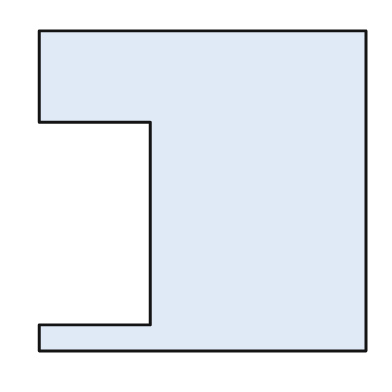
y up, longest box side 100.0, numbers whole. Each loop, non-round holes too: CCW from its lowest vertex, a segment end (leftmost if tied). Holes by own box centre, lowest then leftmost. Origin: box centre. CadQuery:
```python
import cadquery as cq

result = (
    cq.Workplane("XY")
    .moveTo(-50.0, -49.0)
    .lineTo(50.0, -49.0)
    .lineTo(50.0, 49.0)
    .lineTo(-50.0, 49.0)
    .lineTo(-50.0, 21.0)
    .lineTo(-16.0, 21.0)
    .lineTo(-16.0, -41.0)
    .lineTo(-50.0, -41.0)
    .close()
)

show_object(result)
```